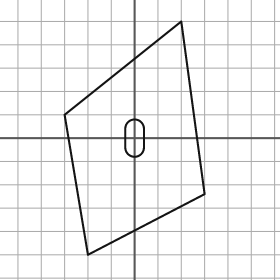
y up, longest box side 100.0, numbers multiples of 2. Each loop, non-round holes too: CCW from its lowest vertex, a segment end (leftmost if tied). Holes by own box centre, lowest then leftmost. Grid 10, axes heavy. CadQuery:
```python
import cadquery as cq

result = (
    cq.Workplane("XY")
    .moveTo(-20.0, -50.0)
    .lineTo(30.0, -24.0)
    .lineTo(20.0, 50.0)
    .lineTo(-30.0, 10.0)
    .close()
    .moveTo(-4.0, -4.0)
    .threePointArc((0.0, -8.0), (4.0, -4.0))
    .lineTo(4.0, 4.0)
    .threePointArc((0.0, 8.0), (-4.0, 4.0))
    .close()
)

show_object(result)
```